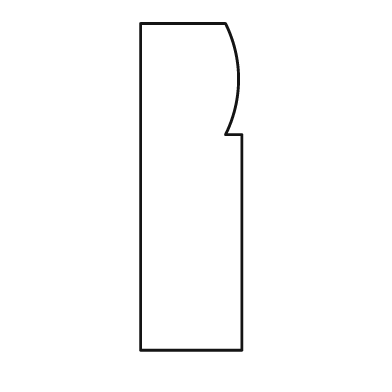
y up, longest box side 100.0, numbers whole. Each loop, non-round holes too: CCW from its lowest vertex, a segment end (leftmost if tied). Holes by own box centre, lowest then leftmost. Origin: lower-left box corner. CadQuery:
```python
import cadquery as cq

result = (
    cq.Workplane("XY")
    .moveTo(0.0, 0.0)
    .lineTo(31.0, 0.0)
    .lineTo(31.0, 66.0)
    .lineTo(26.0, 66.0)
    .threePointArc((30.0, 83.0), (26.0, 100.0))
    .lineTo(0.0, 100.0)
    .close()
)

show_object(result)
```